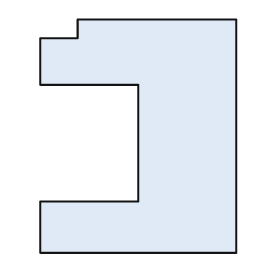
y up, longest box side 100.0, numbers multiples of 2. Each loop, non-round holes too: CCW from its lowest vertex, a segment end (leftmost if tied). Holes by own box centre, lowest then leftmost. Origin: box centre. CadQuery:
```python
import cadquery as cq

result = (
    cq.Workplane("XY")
    .moveTo(-42.0, -50.0)
    .lineTo(42.0, -50.0)
    .lineTo(42.0, 50.0)
    .lineTo(-26.0, 50.0)
    .lineTo(-26.0, 42.0)
    .lineTo(-42.0, 42.0)
    .lineTo(-42.0, 22.0)
    .lineTo(0.0, 22.0)
    .lineTo(0.0, -28.0)
    .lineTo(-42.0, -28.0)
    .close()
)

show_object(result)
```